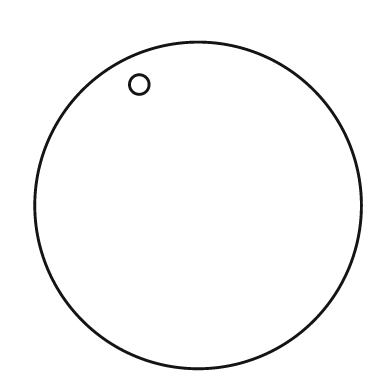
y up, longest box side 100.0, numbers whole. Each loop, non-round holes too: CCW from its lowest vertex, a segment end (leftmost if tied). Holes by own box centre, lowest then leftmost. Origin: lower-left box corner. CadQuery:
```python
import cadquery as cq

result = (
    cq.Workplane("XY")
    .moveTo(50.0, 50.0)
    .circle(50.0)
    .moveTo(32.0, 87.0)
    .circle(3.0)
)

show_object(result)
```